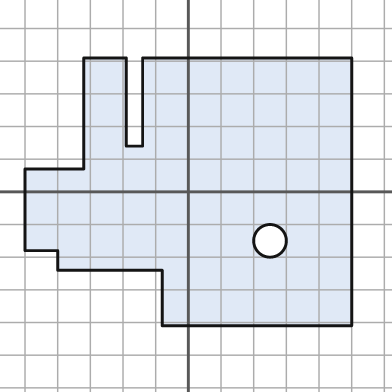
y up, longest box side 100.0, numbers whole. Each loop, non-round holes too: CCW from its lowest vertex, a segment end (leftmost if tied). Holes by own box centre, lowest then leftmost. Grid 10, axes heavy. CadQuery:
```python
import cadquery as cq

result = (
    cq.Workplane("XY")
    .moveTo(-8.0, -41.0)
    .lineTo(50.0, -41.0)
    .lineTo(50.0, 41.0)
    .lineTo(-14.0, 41.0)
    .lineTo(-14.0, 14.0)
    .lineTo(-19.0, 14.0)
    .lineTo(-19.0, 41.0)
    .lineTo(-32.0, 41.0)
    .lineTo(-32.0, 7.0)
    .lineTo(-50.0, 7.0)
    .lineTo(-50.0, -18.0)
    .lineTo(-40.0, -18.0)
    .lineTo(-40.0, -24.0)
    .lineTo(-8.0, -24.0)
    .close()
    .moveTo(25.0, -15.0)
    .circle(5.0)
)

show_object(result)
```